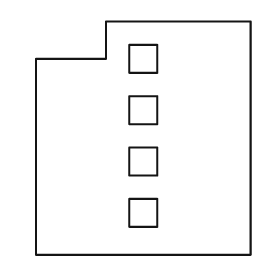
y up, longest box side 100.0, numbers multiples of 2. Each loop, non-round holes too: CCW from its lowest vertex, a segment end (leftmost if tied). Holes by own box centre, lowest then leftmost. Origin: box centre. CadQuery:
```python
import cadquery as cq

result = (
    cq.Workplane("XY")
    .moveTo(-46.0, -50.0)
    .lineTo(46.0, -50.0)
    .lineTo(46.0, 50.0)
    .lineTo(-16.0, 50.0)
    .lineTo(-16.0, 34.0)
    .lineTo(-46.0, 34.0)
    .close()
    .moveTo(-6.0, -38.0)
    .lineTo(6.0, -38.0)
    .lineTo(6.0, -26.0)
    .lineTo(-6.0, -26.0)
    .close()
    .moveTo(-6.0, -16.0)
    .lineTo(6.0, -16.0)
    .lineTo(6.0, -4.0)
    .lineTo(-6.0, -4.0)
    .close()
    .moveTo(-6.0, 6.0)
    .lineTo(6.0, 6.0)
    .lineTo(6.0, 18.0)
    .lineTo(-6.0, 18.0)
    .close()
    .moveTo(-6.0, 28.0)
    .lineTo(6.0, 28.0)
    .lineTo(6.0, 40.0)
    .lineTo(-6.0, 40.0)
    .close()
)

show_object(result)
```